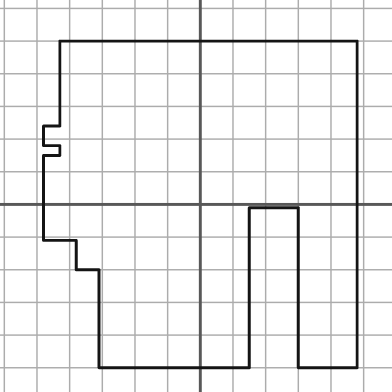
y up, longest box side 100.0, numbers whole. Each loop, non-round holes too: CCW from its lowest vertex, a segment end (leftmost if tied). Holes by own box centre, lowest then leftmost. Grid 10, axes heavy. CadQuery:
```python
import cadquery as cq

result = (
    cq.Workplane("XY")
    .moveTo(-31.0, -50.0)
    .lineTo(15.0, -50.0)
    .lineTo(15.0, -1.0)
    .lineTo(30.0, -1.0)
    .lineTo(30.0, -50.0)
    .lineTo(48.0, -50.0)
    .lineTo(48.0, 50.0)
    .lineTo(-43.0, 50.0)
    .lineTo(-43.0, 24.0)
    .lineTo(-48.0, 24.0)
    .lineTo(-48.0, 18.0)
    .lineTo(-43.0, 18.0)
    .lineTo(-43.0, 15.0)
    .lineTo(-48.0, 15.0)
    .lineTo(-48.0, -11.0)
    .lineTo(-38.0, -11.0)
    .lineTo(-38.0, -20.0)
    .lineTo(-31.0, -20.0)
    .close()
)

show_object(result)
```